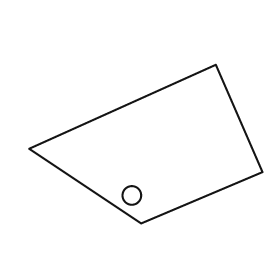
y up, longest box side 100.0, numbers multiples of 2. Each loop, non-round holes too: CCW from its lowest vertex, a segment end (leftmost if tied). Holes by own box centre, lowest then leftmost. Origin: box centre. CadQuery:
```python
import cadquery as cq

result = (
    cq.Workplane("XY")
    .moveTo(-2.0, -34.0)
    .lineTo(50.0, -12.0)
    .lineTo(30.0, 34.0)
    .lineTo(-50.0, -2.0)
    .close()
    .moveTo(-6.0, -22.0)
    .circle(4.0)
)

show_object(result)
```